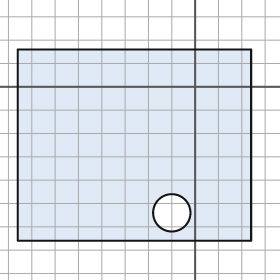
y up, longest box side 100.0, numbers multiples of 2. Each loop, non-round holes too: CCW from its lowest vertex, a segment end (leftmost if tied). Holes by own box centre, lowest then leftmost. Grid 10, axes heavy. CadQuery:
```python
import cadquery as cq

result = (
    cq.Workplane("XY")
    .moveTo(-76.0, -66.0)
    .lineTo(24.0, -66.0)
    .lineTo(24.0, 16.0)
    .lineTo(-76.0, 16.0)
    .close()
    .moveTo(-10.0, -54.0)
    .circle(8.0)
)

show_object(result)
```